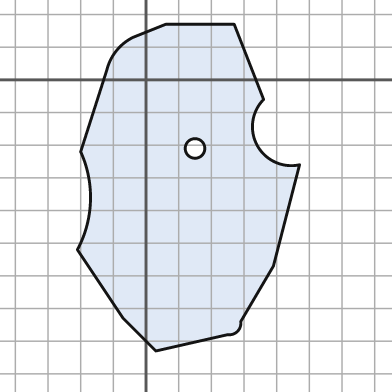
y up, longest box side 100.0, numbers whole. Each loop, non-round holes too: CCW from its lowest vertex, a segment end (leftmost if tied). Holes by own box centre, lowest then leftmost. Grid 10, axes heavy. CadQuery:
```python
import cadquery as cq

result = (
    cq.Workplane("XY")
    .moveTo(3.0, -83.0)
    .lineTo(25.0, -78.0)
    .threePointArc((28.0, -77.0), (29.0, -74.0))
    .lineTo(39.0, -57.0)
    .lineTo(47.0, -26.0)
    .threePointArc((34.0, -20.0), (36.0, -6.0))
    .lineTo(27.0, 17.0)
    .lineTo(6.0, 17.0)
    .lineTo(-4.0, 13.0)
    .threePointArc((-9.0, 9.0), (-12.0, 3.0))
    .lineTo(-20.0, -22.0)
    .threePointArc((-17.0, -37.0), (-21.0, -52.0))
    .lineTo(-7.0, -73.0)
    .close()
    .moveTo(15.0, -21.0)
    .circle(3.0)
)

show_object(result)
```